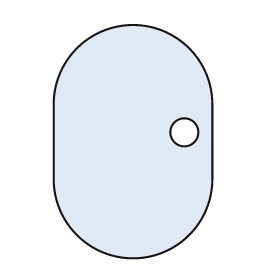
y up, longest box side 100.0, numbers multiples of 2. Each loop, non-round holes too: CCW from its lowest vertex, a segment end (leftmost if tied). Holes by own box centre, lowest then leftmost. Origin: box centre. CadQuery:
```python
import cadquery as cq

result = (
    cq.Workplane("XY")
    .moveTo(-34.0, -16.0)
    .threePointArc((0.0, -50.0), (34.0, -16.0))
    .lineTo(34.0, 16.0)
    .threePointArc((0.0, 50.0), (-34.0, 16.0))
    .close()
    .moveTo(22.0, 4.0)
    .circle(6.0)
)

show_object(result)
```